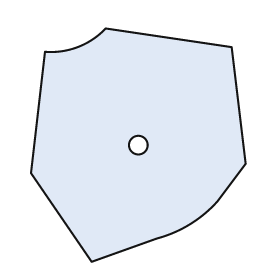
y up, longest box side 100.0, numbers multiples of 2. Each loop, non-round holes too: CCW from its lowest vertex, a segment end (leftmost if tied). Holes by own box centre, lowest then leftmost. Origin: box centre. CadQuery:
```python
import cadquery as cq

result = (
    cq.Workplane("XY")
    .moveTo(-20.0, -50.0)
    .lineTo(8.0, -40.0)
    .threePointArc((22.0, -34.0), (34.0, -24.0))
    .lineTo(46.0, -8.0)
    .lineTo(40.0, 42.0)
    .lineTo(-14.0, 50.0)
    .threePointArc((-26.0, 42.0), (-40.0, 40.0))
    .lineTo(-46.0, -12.0)
    .close()
    .moveTo(0.0, 0.0)
    .circle(4.0)
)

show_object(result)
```